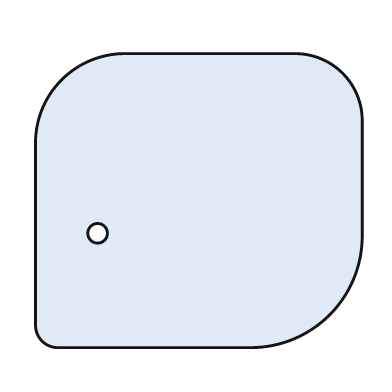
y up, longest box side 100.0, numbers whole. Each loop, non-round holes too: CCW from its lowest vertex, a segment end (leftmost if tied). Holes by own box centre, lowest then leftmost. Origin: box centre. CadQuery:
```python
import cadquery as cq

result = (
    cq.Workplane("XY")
    .moveTo(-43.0, -45.0)
    .lineTo(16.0, -45.0)
    .threePointArc((40.0, -35.0), (50.0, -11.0))
    .lineTo(50.0, 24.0)
    .threePointArc((44.0, 39.0), (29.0, 45.0))
    .lineTo(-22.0, 45.0)
    .threePointArc((-42.0, 37.0), (-50.0, 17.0))
    .lineTo(-50.0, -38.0)
    .threePointArc((-48.0, -43.0), (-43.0, -45.0))
    .close()
    .moveTo(-31.0, -10.0)
    .circle(3.0)
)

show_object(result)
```